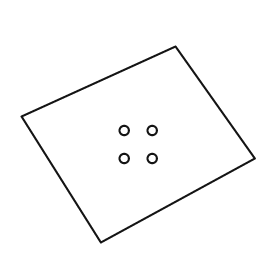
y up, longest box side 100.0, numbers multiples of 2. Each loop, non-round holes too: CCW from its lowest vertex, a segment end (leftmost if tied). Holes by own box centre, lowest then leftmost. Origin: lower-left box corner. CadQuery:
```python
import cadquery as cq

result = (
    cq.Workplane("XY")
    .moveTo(34.0, 0.0)
    .lineTo(100.0, 36.0)
    .lineTo(66.0, 84.0)
    .lineTo(0.0, 54.0)
    .close()
    .moveTo(44.0, 36.0)
    .circle(2.0)
    .moveTo(56.0, 36.0)
    .circle(2.0)
    .moveTo(44.0, 48.0)
    .circle(2.0)
    .moveTo(56.0, 48.0)
    .circle(2.0)
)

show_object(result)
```